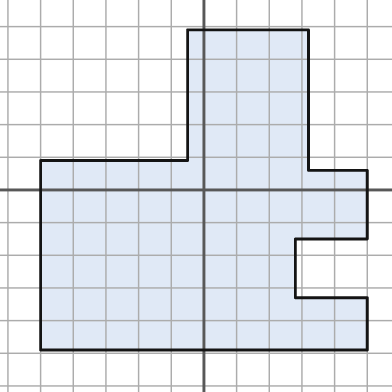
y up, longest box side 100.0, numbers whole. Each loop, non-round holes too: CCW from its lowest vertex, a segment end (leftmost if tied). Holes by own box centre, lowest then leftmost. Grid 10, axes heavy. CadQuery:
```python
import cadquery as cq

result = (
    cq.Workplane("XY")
    .moveTo(-50.0, -49.0)
    .lineTo(50.0, -49.0)
    .lineTo(50.0, -33.0)
    .lineTo(28.0, -33.0)
    .lineTo(28.0, -15.0)
    .lineTo(50.0, -15.0)
    .lineTo(50.0, 6.0)
    .lineTo(32.0, 6.0)
    .lineTo(32.0, 49.0)
    .lineTo(-5.0, 49.0)
    .lineTo(-5.0, 9.0)
    .lineTo(-50.0, 9.0)
    .close()
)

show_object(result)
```